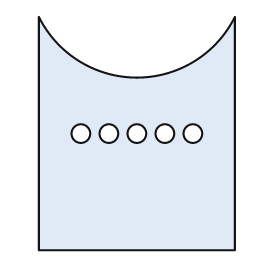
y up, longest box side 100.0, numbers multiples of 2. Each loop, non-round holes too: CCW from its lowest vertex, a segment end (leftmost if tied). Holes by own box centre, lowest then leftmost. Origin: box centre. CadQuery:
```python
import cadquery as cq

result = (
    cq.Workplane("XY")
    .moveTo(-42.0, -50.0)
    .lineTo(42.0, -50.0)
    .lineTo(42.0, 50.0)
    .threePointArc((0.0, 24.0), (-42.0, 50.0))
    .close()
    .moveTo(-24.0, 0.0)
    .circle(4.0)
    .moveTo(-12.0, 0.0)
    .circle(4.0)
    .moveTo(0.0, 0.0)
    .circle(4.0)
    .moveTo(12.0, 0.0)
    .circle(4.0)
    .moveTo(24.0, 0.0)
    .circle(4.0)
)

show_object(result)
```